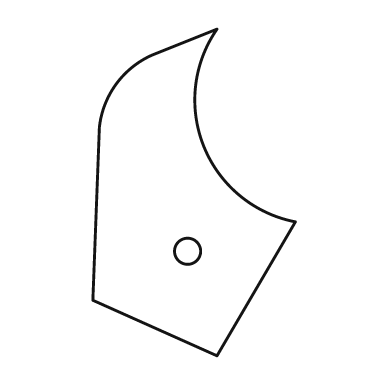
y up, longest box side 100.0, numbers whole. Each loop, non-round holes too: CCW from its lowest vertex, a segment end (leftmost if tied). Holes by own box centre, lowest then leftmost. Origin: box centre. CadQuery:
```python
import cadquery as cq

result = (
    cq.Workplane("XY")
    .moveTo(7.0, -50.0)
    .lineTo(31.0, -9.0)
    .threePointArc((3.0, 14.0), (7.0, 50.0))
    .lineTo(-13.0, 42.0)
    .threePointArc((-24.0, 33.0), (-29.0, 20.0))
    .lineTo(-31.0, -33.0)
    .close()
    .moveTo(-2.0, -18.0)
    .circle(4.0)
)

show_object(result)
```